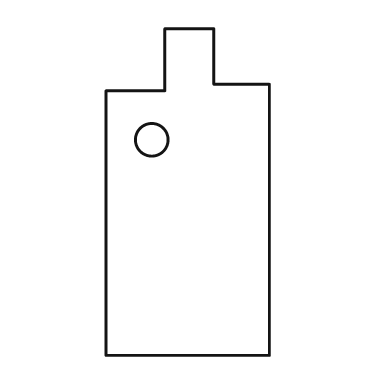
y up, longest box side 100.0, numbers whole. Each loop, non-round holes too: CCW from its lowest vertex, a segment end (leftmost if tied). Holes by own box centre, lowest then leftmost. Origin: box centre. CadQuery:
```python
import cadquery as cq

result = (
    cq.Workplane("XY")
    .moveTo(-25.0, -50.0)
    .lineTo(25.0, -50.0)
    .lineTo(25.0, 33.0)
    .lineTo(8.0, 33.0)
    .lineTo(8.0, 50.0)
    .lineTo(-7.0, 50.0)
    .lineTo(-7.0, 31.0)
    .lineTo(-25.0, 31.0)
    .close()
    .moveTo(-11.0, 16.0)
    .circle(5.0)
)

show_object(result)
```